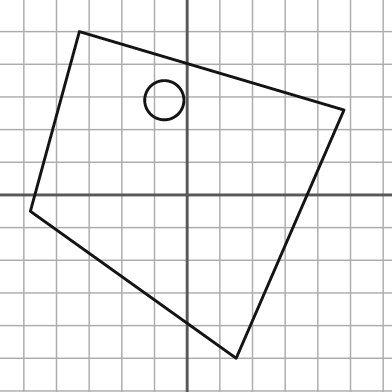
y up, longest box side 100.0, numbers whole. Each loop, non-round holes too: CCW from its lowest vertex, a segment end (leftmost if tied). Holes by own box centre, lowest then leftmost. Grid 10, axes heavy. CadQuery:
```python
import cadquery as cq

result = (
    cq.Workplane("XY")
    .moveTo(15.0, -50.0)
    .lineTo(48.0, 26.0)
    .lineTo(-33.0, 50.0)
    .lineTo(-48.0, -5.0)
    .close()
    .moveTo(-7.0, 29.0)
    .circle(6.0)
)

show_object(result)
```